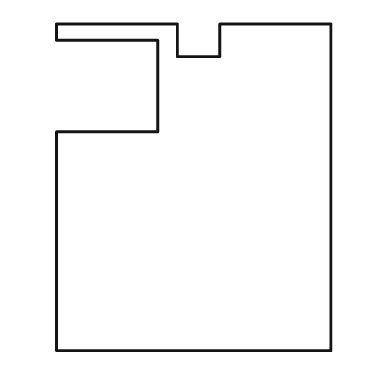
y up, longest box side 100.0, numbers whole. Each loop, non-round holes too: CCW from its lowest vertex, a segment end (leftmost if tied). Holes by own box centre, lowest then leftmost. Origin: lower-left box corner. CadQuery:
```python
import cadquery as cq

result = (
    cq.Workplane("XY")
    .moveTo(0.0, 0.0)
    .lineTo(84.0, 0.0)
    .lineTo(84.0, 100.0)
    .lineTo(50.0, 100.0)
    .lineTo(50.0, 90.0)
    .lineTo(37.0, 90.0)
    .lineTo(37.0, 100.0)
    .lineTo(0.0, 100.0)
    .lineTo(0.0, 95.0)
    .lineTo(31.0, 95.0)
    .lineTo(31.0, 67.0)
    .lineTo(0.0, 67.0)
    .close()
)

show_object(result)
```